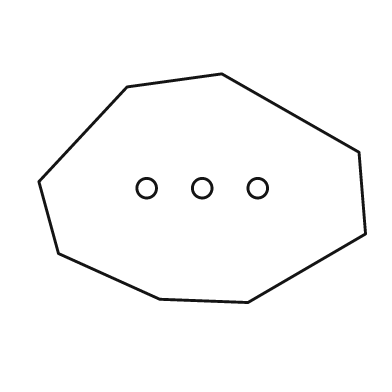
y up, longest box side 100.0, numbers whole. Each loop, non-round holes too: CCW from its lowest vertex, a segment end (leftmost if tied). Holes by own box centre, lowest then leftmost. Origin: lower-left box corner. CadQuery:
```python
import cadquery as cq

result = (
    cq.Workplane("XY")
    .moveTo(64.0, 0.0)
    .lineTo(100.0, 21.0)
    .lineTo(98.0, 46.0)
    .lineTo(56.0, 70.0)
    .lineTo(27.0, 66.0)
    .lineTo(0.0, 37.0)
    .lineTo(6.0, 15.0)
    .lineTo(37.0, 1.0)
    .close()
    .moveTo(33.0, 35.0)
    .circle(3.0)
    .moveTo(50.0, 35.0)
    .circle(3.0)
    .moveTo(67.0, 35.0)
    .circle(3.0)
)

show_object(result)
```